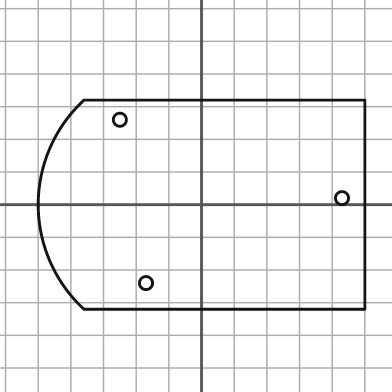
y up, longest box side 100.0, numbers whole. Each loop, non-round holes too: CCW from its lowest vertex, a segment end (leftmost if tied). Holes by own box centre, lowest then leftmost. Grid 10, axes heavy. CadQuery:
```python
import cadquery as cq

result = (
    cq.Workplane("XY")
    .moveTo(-36.0, -32.0)
    .lineTo(50.0, -32.0)
    .lineTo(50.0, 32.0)
    .lineTo(-36.0, 32.0)
    .threePointArc((-50.0, 0.0), (-36.0, -32.0))
    .close()
    .moveTo(-17.0, -24.0)
    .circle(2.0)
    .moveTo(43.0, 2.0)
    .circle(2.0)
    .moveTo(-25.0, 26.0)
    .circle(2.0)
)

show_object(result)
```